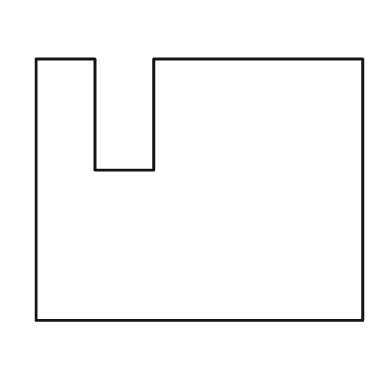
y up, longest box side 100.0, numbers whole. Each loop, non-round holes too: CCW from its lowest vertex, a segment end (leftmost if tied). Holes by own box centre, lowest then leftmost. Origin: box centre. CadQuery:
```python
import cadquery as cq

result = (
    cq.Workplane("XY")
    .moveTo(-50.0, -40.0)
    .lineTo(50.0, -40.0)
    .lineTo(50.0, 40.0)
    .lineTo(-14.0, 40.0)
    .lineTo(-14.0, 6.0)
    .lineTo(-32.0, 6.0)
    .lineTo(-32.0, 40.0)
    .lineTo(-50.0, 40.0)
    .close()
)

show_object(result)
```